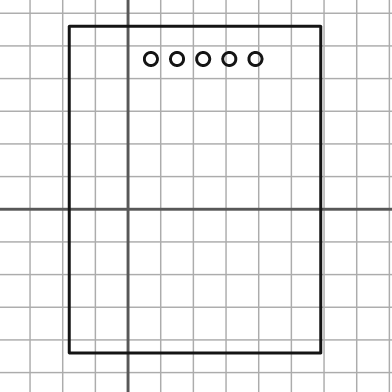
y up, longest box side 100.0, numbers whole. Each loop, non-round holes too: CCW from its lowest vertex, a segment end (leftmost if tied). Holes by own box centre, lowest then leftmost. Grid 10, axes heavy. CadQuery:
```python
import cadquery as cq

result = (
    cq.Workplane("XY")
    .moveTo(-18.0, -44.0)
    .lineTo(59.0, -44.0)
    .lineTo(59.0, 56.0)
    .lineTo(-18.0, 56.0)
    .close()
    .moveTo(7.0, 46.0)
    .circle(2.0)
    .moveTo(15.0, 46.0)
    .circle(2.0)
    .moveTo(23.0, 46.0)
    .circle(2.0)
    .moveTo(31.0, 46.0)
    .circle(2.0)
    .moveTo(39.0, 46.0)
    .circle(2.0)
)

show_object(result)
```